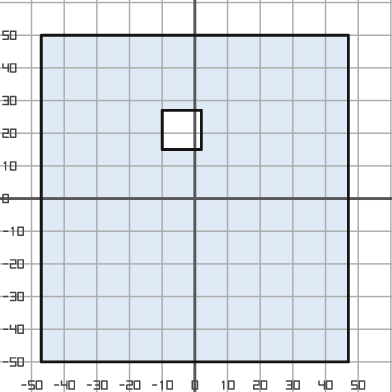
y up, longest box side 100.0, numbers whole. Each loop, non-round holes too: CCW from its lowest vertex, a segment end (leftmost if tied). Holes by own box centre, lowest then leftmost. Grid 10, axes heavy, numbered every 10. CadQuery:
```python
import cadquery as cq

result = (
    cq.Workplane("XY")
    .moveTo(-47.0, -50.0)
    .lineTo(47.0, -50.0)
    .lineTo(47.0, 50.0)
    .lineTo(-47.0, 50.0)
    .close()
    .moveTo(-10.0, 15.0)
    .lineTo(2.0, 15.0)
    .lineTo(2.0, 27.0)
    .lineTo(-10.0, 27.0)
    .close()
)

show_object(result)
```